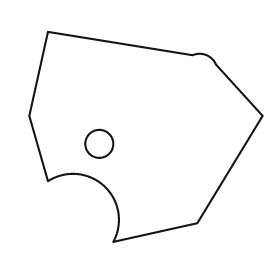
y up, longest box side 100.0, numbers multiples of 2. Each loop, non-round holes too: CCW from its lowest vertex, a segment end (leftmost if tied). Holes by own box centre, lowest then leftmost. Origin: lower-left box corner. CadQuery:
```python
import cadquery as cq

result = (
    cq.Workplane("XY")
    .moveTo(36.0, 0.0)
    .lineTo(72.0, 8.0)
    .lineTo(100.0, 54.0)
    .lineTo(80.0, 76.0)
    .threePointArc((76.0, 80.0), (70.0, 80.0))
    .lineTo(8.0, 90.0)
    .lineTo(0.0, 54.0)
    .lineTo(8.0, 26.0)
    .threePointArc((32.0, 24.0), (36.0, 0.0))
    .close()
    .moveTo(30.0, 42.0)
    .circle(6.0)
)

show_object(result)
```